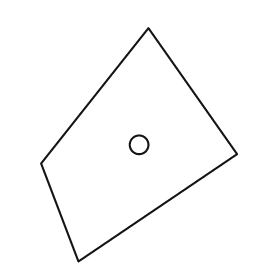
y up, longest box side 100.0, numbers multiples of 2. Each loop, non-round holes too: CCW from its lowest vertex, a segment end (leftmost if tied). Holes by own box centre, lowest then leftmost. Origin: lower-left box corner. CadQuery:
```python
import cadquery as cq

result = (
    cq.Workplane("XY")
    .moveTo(16.0, 0.0)
    .lineTo(84.0, 46.0)
    .lineTo(46.0, 100.0)
    .lineTo(0.0, 42.0)
    .close()
    .moveTo(42.0, 50.0)
    .circle(4.0)
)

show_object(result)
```